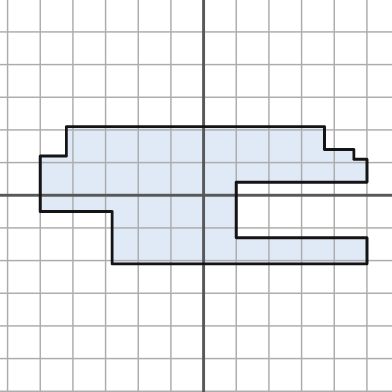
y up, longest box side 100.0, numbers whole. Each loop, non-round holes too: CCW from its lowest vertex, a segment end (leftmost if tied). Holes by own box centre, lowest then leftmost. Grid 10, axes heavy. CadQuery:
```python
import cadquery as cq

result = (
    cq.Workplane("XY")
    .moveTo(-28.0, -21.0)
    .lineTo(50.0, -21.0)
    .lineTo(50.0, -13.0)
    .lineTo(10.0, -13.0)
    .lineTo(10.0, 4.0)
    .lineTo(50.0, 4.0)
    .lineTo(50.0, 11.0)
    .lineTo(46.0, 11.0)
    .lineTo(46.0, 14.0)
    .lineTo(37.0, 14.0)
    .lineTo(37.0, 21.0)
    .lineTo(-42.0, 21.0)
    .lineTo(-42.0, 12.0)
    .lineTo(-50.0, 12.0)
    .lineTo(-50.0, -5.0)
    .lineTo(-28.0, -5.0)
    .close()
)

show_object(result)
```